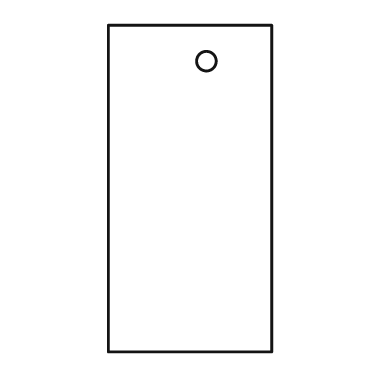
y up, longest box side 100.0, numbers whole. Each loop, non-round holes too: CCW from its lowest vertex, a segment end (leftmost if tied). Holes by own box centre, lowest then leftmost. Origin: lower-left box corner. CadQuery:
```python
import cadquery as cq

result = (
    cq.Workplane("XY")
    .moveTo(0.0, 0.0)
    .lineTo(50.0, 0.0)
    .lineTo(50.0, 100.0)
    .lineTo(0.0, 100.0)
    .close()
    .moveTo(30.0, 89.0)
    .circle(3.0)
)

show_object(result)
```